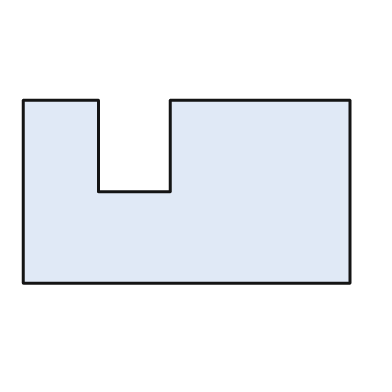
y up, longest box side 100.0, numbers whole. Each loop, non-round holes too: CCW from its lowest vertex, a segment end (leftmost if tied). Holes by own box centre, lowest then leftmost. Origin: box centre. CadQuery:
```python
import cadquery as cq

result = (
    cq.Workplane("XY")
    .moveTo(-50.0, -28.0)
    .lineTo(50.0, -28.0)
    .lineTo(50.0, 28.0)
    .lineTo(-5.0, 28.0)
    .lineTo(-5.0, 0.0)
    .lineTo(-27.0, 0.0)
    .lineTo(-27.0, 28.0)
    .lineTo(-50.0, 28.0)
    .close()
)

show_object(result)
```